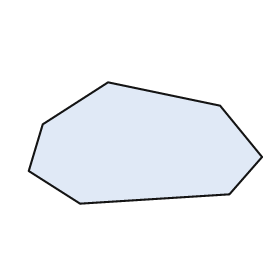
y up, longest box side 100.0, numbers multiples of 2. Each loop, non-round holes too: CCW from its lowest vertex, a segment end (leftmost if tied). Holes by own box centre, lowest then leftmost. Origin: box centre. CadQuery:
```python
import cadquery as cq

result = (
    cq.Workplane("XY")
    .moveTo(-28.0, -26.0)
    .lineTo(36.0, -22.0)
    .lineTo(50.0, -6.0)
    .lineTo(32.0, 16.0)
    .lineTo(-16.0, 26.0)
    .lineTo(-44.0, 8.0)
    .lineTo(-50.0, -12.0)
    .close()
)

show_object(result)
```